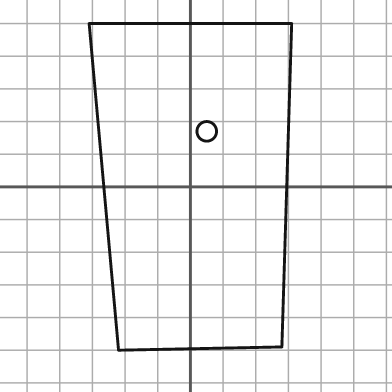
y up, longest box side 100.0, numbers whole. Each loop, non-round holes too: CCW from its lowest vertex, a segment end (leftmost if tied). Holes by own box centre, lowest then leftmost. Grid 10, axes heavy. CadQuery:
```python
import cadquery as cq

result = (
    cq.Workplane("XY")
    .moveTo(-22.0, -50.0)
    .lineTo(28.0, -49.0)
    .lineTo(31.0, 50.0)
    .lineTo(-31.0, 50.0)
    .close()
    .moveTo(5.0, 17.0)
    .circle(3.0)
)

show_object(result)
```